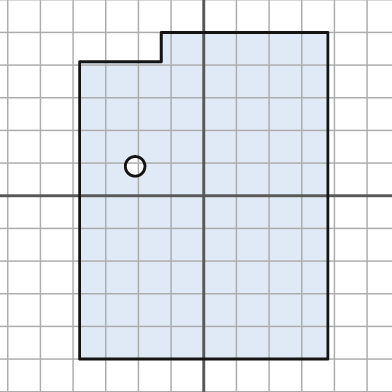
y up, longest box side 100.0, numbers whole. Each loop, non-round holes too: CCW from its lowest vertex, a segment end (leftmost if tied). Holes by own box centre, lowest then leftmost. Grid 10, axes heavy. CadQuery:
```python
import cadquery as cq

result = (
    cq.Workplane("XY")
    .moveTo(-38.0, -50.0)
    .lineTo(38.0, -50.0)
    .lineTo(38.0, 50.0)
    .lineTo(-13.0, 50.0)
    .lineTo(-13.0, 41.0)
    .lineTo(-38.0, 41.0)
    .close()
    .moveTo(-21.0, 9.0)
    .circle(3.0)
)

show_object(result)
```